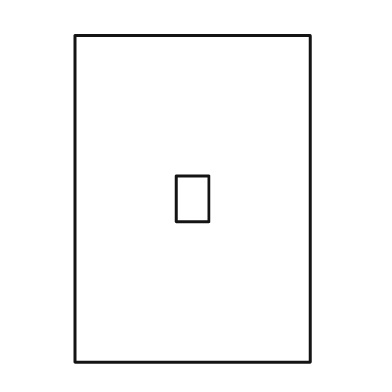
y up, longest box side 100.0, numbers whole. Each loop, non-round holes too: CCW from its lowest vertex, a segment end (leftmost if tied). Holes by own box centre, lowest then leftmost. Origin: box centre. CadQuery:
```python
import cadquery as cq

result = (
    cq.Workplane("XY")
    .moveTo(-36.0, -50.0)
    .lineTo(36.0, -50.0)
    .lineTo(36.0, 50.0)
    .lineTo(-36.0, 50.0)
    .close()
    .moveTo(-5.0, -7.0)
    .lineTo(5.0, -7.0)
    .lineTo(5.0, 7.0)
    .lineTo(-5.0, 7.0)
    .close()
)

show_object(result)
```